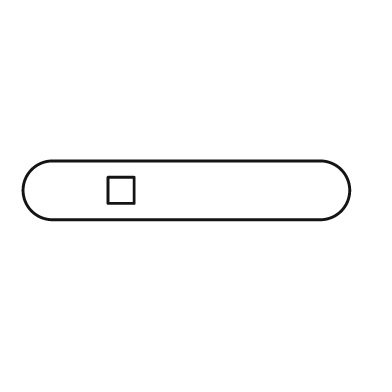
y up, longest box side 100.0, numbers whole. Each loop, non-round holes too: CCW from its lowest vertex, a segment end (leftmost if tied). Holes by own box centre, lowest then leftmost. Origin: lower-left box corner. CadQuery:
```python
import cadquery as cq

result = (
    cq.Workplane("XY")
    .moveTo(9.0, 0.0)
    .lineTo(91.0, 0.0)
    .threePointArc((100.0, 9.0), (91.0, 18.0))
    .lineTo(9.0, 18.0)
    .threePointArc((0.0, 9.0), (9.0, 0.0))
    .close()
    .moveTo(26.0, 5.0)
    .lineTo(34.0, 5.0)
    .lineTo(34.0, 13.0)
    .lineTo(26.0, 13.0)
    .close()
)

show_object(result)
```